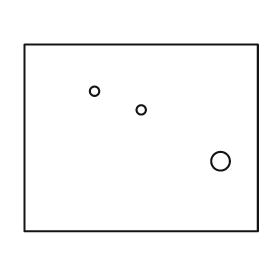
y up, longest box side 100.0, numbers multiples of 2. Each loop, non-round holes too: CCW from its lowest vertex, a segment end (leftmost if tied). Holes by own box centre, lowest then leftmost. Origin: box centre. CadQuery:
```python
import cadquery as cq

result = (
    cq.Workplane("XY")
    .moveTo(-50.0, -40.0)
    .lineTo(50.0, -40.0)
    .lineTo(50.0, 40.0)
    .lineTo(-50.0, 40.0)
    .close()
    .moveTo(34.0, -10.0)
    .circle(4.0)
    .moveTo(0.0, 12.0)
    .circle(2.0)
    .moveTo(-20.0, 20.0)
    .circle(2.0)
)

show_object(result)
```